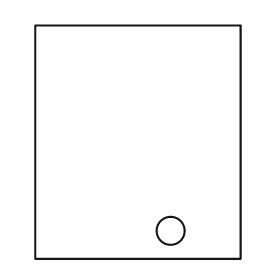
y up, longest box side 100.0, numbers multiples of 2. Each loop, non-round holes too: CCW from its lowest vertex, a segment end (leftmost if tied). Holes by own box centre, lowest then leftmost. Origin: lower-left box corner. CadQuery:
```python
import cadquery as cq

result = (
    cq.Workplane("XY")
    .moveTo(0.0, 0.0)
    .lineTo(88.0, 0.0)
    .lineTo(88.0, 100.0)
    .lineTo(0.0, 100.0)
    .close()
    .moveTo(58.0, 12.0)
    .circle(6.0)
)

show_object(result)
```